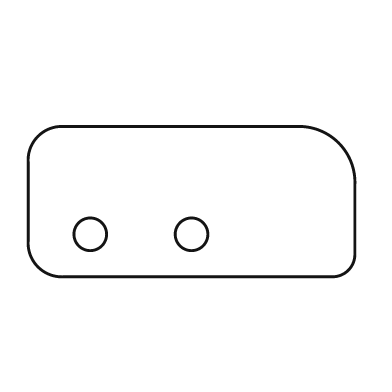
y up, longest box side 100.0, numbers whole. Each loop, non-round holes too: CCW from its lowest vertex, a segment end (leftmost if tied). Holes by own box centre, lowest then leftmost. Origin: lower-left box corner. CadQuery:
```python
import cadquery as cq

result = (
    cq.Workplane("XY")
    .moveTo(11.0, 0.0)
    .lineTo(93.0, 0.0)
    .threePointArc((98.0, 2.0), (100.0, 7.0))
    .lineTo(100.0, 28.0)
    .threePointArc((95.0, 41.0), (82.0, 46.0))
    .lineTo(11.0, 46.0)
    .threePointArc((3.0, 43.0), (0.0, 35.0))
    .lineTo(0.0, 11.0)
    .threePointArc((3.0, 3.0), (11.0, 0.0))
    .close()
    .moveTo(19.0, 13.0)
    .circle(5.0)
    .moveTo(50.0, 13.0)
    .circle(5.0)
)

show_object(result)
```